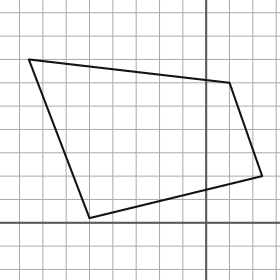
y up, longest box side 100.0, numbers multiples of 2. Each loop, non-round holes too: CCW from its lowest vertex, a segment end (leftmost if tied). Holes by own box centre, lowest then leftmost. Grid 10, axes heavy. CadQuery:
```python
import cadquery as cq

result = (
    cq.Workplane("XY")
    .moveTo(-50.0, 2.0)
    .lineTo(24.0, 20.0)
    .lineTo(10.0, 60.0)
    .lineTo(-76.0, 70.0)
    .close()
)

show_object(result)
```